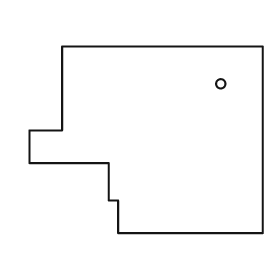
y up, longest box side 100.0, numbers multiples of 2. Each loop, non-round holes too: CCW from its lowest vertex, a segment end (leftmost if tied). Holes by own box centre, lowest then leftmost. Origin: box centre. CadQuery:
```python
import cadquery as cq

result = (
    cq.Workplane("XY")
    .moveTo(-12.0, -40.0)
    .lineTo(50.0, -40.0)
    .lineTo(50.0, 40.0)
    .lineTo(-36.0, 40.0)
    .lineTo(-36.0, 4.0)
    .lineTo(-50.0, 4.0)
    .lineTo(-50.0, -10.0)
    .lineTo(-16.0, -10.0)
    .lineTo(-16.0, -26.0)
    .lineTo(-12.0, -26.0)
    .close()
    .moveTo(32.0, 24.0)
    .circle(2.0)
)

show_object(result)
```